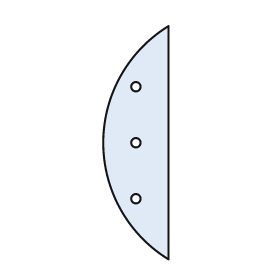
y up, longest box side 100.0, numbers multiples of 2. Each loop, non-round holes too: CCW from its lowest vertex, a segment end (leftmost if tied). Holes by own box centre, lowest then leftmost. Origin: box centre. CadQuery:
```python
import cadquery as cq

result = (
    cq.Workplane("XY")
    .moveTo(14.0, -50.0)
    .lineTo(14.0, 50.0)
    .threePointArc((-14.0, 0.0), (14.0, -50.0))
    .close()
    .moveTo(0.0, -24.0)
    .circle(2.0)
    .moveTo(0.0, 0.0)
    .circle(2.0)
    .moveTo(0.0, 24.0)
    .circle(2.0)
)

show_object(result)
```